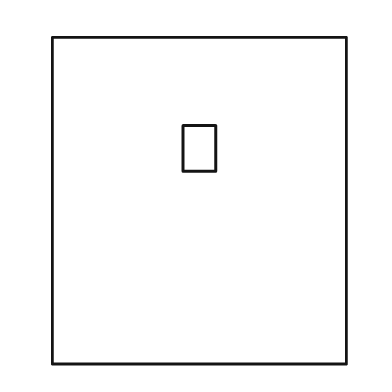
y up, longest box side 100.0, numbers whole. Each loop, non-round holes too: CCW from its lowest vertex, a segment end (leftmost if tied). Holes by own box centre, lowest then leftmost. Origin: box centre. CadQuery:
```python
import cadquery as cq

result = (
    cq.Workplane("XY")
    .moveTo(-45.0, -50.0)
    .lineTo(45.0, -50.0)
    .lineTo(45.0, 50.0)
    .lineTo(-45.0, 50.0)
    .close()
    .moveTo(-5.0, 9.0)
    .lineTo(5.0, 9.0)
    .lineTo(5.0, 23.0)
    .lineTo(-5.0, 23.0)
    .close()
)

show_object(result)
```